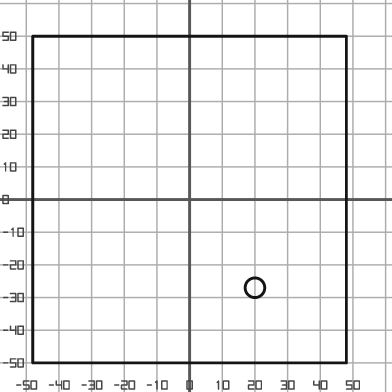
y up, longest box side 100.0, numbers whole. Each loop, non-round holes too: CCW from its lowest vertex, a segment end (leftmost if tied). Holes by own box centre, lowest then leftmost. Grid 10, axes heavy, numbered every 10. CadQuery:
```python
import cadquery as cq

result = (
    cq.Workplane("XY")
    .moveTo(-48.0, -50.0)
    .lineTo(48.0, -50.0)
    .lineTo(48.0, 50.0)
    .lineTo(-48.0, 50.0)
    .close()
    .moveTo(20.0, -27.0)
    .circle(3.0)
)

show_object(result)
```